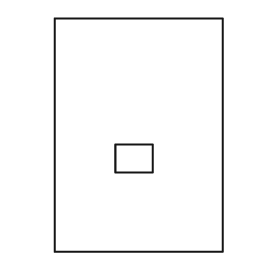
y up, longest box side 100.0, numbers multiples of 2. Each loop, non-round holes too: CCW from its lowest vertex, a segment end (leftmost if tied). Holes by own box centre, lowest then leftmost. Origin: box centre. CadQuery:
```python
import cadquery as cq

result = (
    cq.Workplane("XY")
    .moveTo(-36.0, -50.0)
    .lineTo(36.0, -50.0)
    .lineTo(36.0, 50.0)
    .lineTo(-36.0, 50.0)
    .close()
    .moveTo(-10.0, -16.0)
    .lineTo(6.0, -16.0)
    .lineTo(6.0, -4.0)
    .lineTo(-10.0, -4.0)
    .close()
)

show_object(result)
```